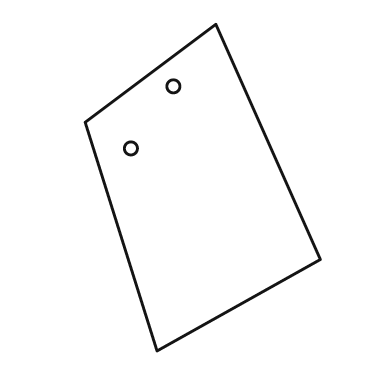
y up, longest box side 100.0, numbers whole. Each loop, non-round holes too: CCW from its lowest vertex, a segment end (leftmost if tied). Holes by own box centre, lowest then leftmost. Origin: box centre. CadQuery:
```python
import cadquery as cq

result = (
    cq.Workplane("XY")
    .moveTo(-14.0, -50.0)
    .lineTo(36.0, -22.0)
    .lineTo(4.0, 50.0)
    .lineTo(-36.0, 20.0)
    .close()
    .moveTo(-22.0, 12.0)
    .circle(2.0)
    .moveTo(-9.0, 31.0)
    .circle(2.0)
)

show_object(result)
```